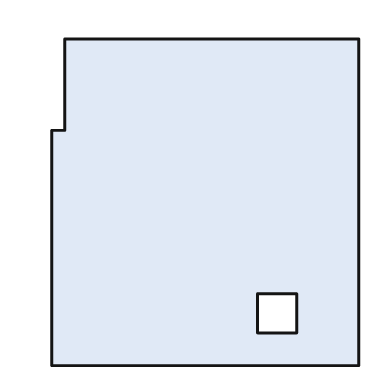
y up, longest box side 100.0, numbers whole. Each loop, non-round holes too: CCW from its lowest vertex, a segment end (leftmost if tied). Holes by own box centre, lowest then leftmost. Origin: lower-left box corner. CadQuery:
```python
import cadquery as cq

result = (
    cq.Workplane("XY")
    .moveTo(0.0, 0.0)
    .lineTo(94.0, 0.0)
    .lineTo(94.0, 100.0)
    .lineTo(4.0, 100.0)
    .lineTo(4.0, 72.0)
    .lineTo(0.0, 72.0)
    .close()
    .moveTo(63.0, 10.0)
    .lineTo(75.0, 10.0)
    .lineTo(75.0, 22.0)
    .lineTo(63.0, 22.0)
    .close()
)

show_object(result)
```